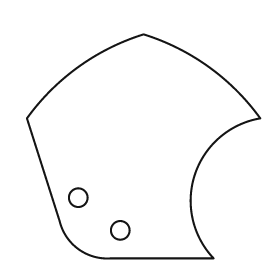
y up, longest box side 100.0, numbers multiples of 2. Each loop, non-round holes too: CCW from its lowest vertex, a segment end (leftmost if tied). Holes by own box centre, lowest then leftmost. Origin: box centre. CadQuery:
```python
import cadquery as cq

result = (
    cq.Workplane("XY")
    .moveTo(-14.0, -48.0)
    .lineTo(30.0, -48.0)
    .threePointArc((22.0, -12.0), (50.0, 12.0))
    .threePointArc((28.0, 34.0), (0.0, 48.0))
    .threePointArc((-28.0, 34.0), (-50.0, 12.0))
    .lineTo(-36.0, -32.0)
    .threePointArc((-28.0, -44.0), (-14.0, -48.0))
    .close()
    .moveTo(-10.0, -36.0)
    .circle(4.0)
    .moveTo(-28.0, -22.0)
    .circle(4.0)
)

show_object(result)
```